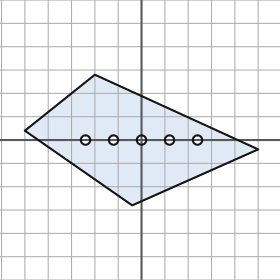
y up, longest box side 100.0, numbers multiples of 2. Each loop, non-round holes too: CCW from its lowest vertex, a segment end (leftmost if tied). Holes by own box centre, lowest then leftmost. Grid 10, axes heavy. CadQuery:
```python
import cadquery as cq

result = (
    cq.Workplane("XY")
    .moveTo(-4.0, -28.0)
    .lineTo(50.0, -4.0)
    .lineTo(-20.0, 28.0)
    .lineTo(-50.0, 4.0)
    .close()
    .moveTo(-24.0, 0.0)
    .circle(2.0)
    .moveTo(-12.0, 0.0)
    .circle(2.0)
    .moveTo(0.0, 0.0)
    .circle(2.0)
    .moveTo(12.0, 0.0)
    .circle(2.0)
    .moveTo(24.0, 0.0)
    .circle(2.0)
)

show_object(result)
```